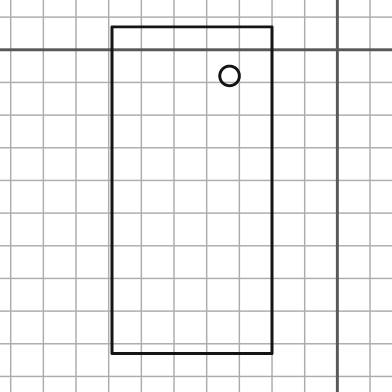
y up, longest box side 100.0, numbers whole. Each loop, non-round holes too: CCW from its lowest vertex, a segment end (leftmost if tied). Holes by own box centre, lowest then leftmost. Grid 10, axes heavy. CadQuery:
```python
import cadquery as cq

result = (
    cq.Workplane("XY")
    .moveTo(-69.0, -93.0)
    .lineTo(-20.0, -93.0)
    .lineTo(-20.0, 7.0)
    .lineTo(-69.0, 7.0)
    .close()
    .moveTo(-33.0, -8.0)
    .circle(3.0)
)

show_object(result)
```